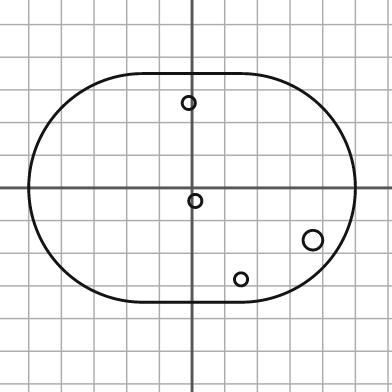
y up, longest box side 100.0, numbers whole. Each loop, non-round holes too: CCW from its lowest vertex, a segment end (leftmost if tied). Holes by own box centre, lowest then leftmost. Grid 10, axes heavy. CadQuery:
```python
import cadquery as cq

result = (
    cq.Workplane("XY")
    .moveTo(-15.0, -35.0)
    .lineTo(15.0, -35.0)
    .threePointArc((50.0, 0.0), (15.0, 35.0))
    .lineTo(-15.0, 35.0)
    .threePointArc((-50.0, 0.0), (-15.0, -35.0))
    .close()
    .moveTo(15.0, -28.0)
    .circle(2.0)
    .moveTo(37.0, -16.0)
    .circle(3.0)
    .moveTo(1.0, -4.0)
    .circle(2.0)
    .moveTo(-1.0, 26.0)
    .circle(2.0)
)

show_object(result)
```